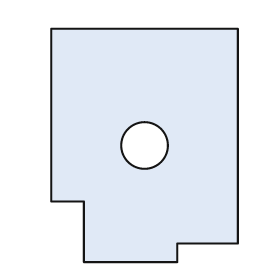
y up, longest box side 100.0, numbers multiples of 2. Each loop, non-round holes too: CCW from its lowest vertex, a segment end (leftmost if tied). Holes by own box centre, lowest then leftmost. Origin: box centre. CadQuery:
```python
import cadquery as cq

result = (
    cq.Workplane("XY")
    .moveTo(-26.0, -50.0)
    .lineTo(14.0, -50.0)
    .lineTo(14.0, -42.0)
    .lineTo(40.0, -42.0)
    .lineTo(40.0, 50.0)
    .lineTo(-40.0, 50.0)
    .lineTo(-40.0, -24.0)
    .lineTo(-26.0, -24.0)
    .close()
    .moveTo(0.0, 0.0)
    .circle(10.0)
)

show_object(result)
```